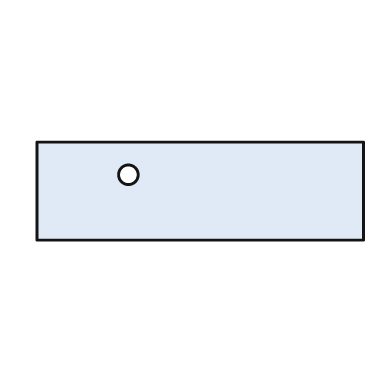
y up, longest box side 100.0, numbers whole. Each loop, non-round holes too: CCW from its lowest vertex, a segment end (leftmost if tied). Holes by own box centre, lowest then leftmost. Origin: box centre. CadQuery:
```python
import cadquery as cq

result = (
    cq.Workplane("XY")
    .moveTo(-50.0, -15.0)
    .lineTo(50.0, -15.0)
    .lineTo(50.0, 15.0)
    .lineTo(-50.0, 15.0)
    .close()
    .moveTo(-22.0, 5.0)
    .circle(3.0)
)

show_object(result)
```